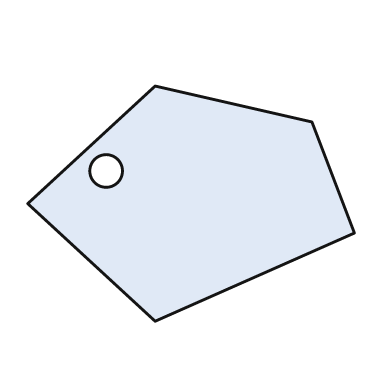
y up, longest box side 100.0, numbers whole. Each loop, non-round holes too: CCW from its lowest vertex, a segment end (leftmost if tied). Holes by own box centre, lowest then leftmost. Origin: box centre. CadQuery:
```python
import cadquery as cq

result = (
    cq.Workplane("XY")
    .moveTo(-11.0, -36.0)
    .lineTo(50.0, -9.0)
    .lineTo(37.0, 25.0)
    .lineTo(-11.0, 36.0)
    .lineTo(-50.0, 0.0)
    .close()
    .moveTo(-26.0, 10.0)
    .circle(5.0)
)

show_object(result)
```